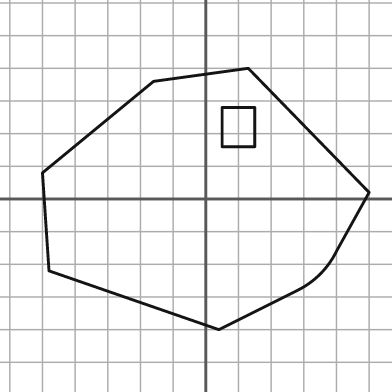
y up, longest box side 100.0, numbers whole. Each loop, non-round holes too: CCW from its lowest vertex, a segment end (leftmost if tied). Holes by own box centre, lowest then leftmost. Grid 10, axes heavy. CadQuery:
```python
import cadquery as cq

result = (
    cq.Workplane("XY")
    .moveTo(4.0, -40.0)
    .lineTo(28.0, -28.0)
    .threePointArc((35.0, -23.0), (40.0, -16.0))
    .lineTo(50.0, 2.0)
    .lineTo(13.0, 40.0)
    .lineTo(-16.0, 36.0)
    .lineTo(-50.0, 8.0)
    .lineTo(-48.0, -22.0)
    .close()
    .moveTo(5.0, 16.0)
    .lineTo(15.0, 16.0)
    .lineTo(15.0, 28.0)
    .lineTo(5.0, 28.0)
    .close()
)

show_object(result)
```